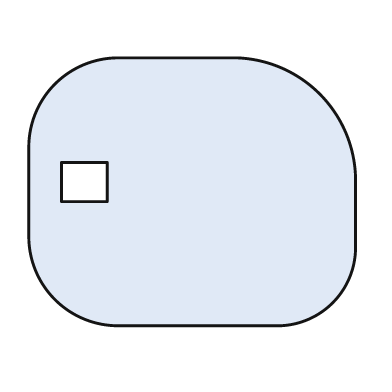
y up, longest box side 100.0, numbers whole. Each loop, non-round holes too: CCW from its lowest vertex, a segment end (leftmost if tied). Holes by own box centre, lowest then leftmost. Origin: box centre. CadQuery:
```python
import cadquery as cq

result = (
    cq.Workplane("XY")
    .moveTo(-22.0, -41.0)
    .lineTo(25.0, -41.0)
    .threePointArc((43.0, -34.0), (50.0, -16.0))
    .lineTo(50.0, 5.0)
    .threePointArc((39.0, 30.0), (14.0, 41.0))
    .lineTo(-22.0, 41.0)
    .threePointArc((-42.0, 33.0), (-50.0, 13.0))
    .lineTo(-50.0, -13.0)
    .threePointArc((-42.0, -33.0), (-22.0, -41.0))
    .close()
    .moveTo(-40.0, -3.0)
    .lineTo(-26.0, -3.0)
    .lineTo(-26.0, 9.0)
    .lineTo(-40.0, 9.0)
    .close()
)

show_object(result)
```